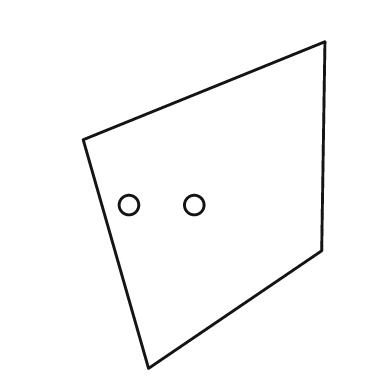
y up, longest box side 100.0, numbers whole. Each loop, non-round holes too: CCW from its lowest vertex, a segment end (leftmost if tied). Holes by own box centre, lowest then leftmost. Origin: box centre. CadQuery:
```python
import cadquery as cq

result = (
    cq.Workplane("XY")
    .moveTo(-17.0, -50.0)
    .lineTo(36.0, -14.0)
    .lineTo(37.0, 50.0)
    .lineTo(-37.0, 20.0)
    .close()
    .moveTo(-23.0, 0.0)
    .circle(3.0)
    .moveTo(-3.0, 0.0)
    .circle(3.0)
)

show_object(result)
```